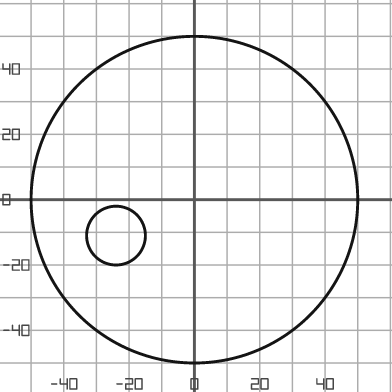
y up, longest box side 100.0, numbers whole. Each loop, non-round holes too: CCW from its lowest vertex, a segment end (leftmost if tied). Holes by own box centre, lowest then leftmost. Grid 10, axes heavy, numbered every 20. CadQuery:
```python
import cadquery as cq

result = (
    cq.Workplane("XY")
    .moveTo(0.0, 0.0)
    .circle(50.0)
    .moveTo(-24.0, -11.0)
    .circle(9.0)
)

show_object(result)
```